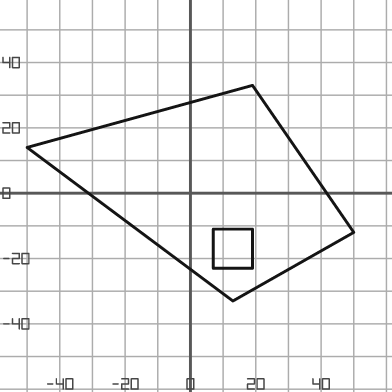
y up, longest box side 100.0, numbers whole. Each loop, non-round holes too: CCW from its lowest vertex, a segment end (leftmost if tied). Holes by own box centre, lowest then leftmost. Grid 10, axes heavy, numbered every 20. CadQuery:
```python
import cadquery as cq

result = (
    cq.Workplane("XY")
    .moveTo(13.0, -33.0)
    .lineTo(50.0, -12.0)
    .lineTo(19.0, 33.0)
    .lineTo(-50.0, 14.0)
    .close()
    .moveTo(7.0, -23.0)
    .lineTo(19.0, -23.0)
    .lineTo(19.0, -11.0)
    .lineTo(7.0, -11.0)
    .close()
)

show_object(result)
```